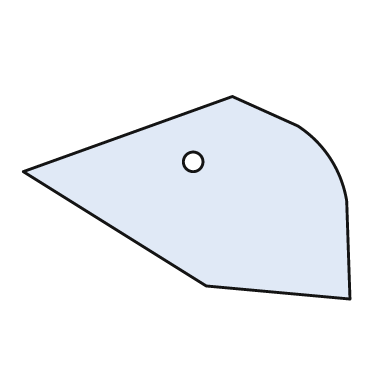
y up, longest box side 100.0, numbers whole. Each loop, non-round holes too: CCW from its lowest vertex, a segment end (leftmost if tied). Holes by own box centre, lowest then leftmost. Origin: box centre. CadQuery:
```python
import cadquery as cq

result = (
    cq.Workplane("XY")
    .moveTo(50.0, -31.0)
    .lineTo(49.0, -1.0)
    .threePointArc((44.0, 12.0), (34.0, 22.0))
    .lineTo(14.0, 31.0)
    .lineTo(-50.0, 8.0)
    .lineTo(6.0, -27.0)
    .close()
    .moveTo(2.0, 11.0)
    .circle(3.0)
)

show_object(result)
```